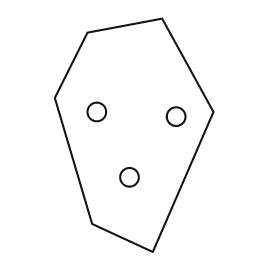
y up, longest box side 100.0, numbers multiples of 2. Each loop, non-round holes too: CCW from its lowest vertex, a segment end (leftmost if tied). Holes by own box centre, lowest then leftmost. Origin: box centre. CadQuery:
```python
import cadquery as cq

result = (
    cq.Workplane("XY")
    .moveTo(8.0, -50.0)
    .lineTo(34.0, 10.0)
    .lineTo(12.0, 50.0)
    .lineTo(-20.0, 44.0)
    .lineTo(-34.0, 16.0)
    .lineTo(-18.0, -38.0)
    .close()
    .moveTo(-2.0, -18.0)
    .circle(4.0)
    .moveTo(18.0, 8.0)
    .circle(4.0)
    .moveTo(-16.0, 10.0)
    .circle(4.0)
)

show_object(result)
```